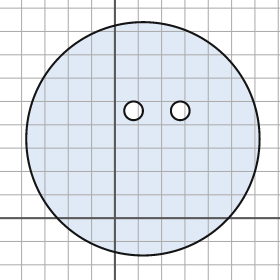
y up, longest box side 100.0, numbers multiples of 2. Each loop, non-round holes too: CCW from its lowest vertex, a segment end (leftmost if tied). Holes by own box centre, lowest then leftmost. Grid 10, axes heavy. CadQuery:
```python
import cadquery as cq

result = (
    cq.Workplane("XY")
    .moveTo(12.0, 34.0)
    .circle(50.0)
    .moveTo(8.0, 46.0)
    .circle(4.0)
    .moveTo(28.0, 46.0)
    .circle(4.0)
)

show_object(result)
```